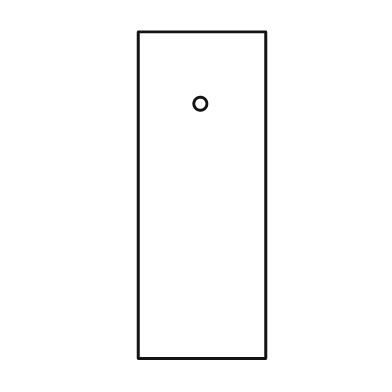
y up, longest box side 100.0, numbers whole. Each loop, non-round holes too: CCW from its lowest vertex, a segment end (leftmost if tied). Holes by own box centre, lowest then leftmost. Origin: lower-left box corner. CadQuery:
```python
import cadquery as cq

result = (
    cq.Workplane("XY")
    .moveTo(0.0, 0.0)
    .lineTo(39.0, 0.0)
    .lineTo(39.0, 100.0)
    .lineTo(0.0, 100.0)
    .close()
    .moveTo(19.0, 78.0)
    .circle(2.0)
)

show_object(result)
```